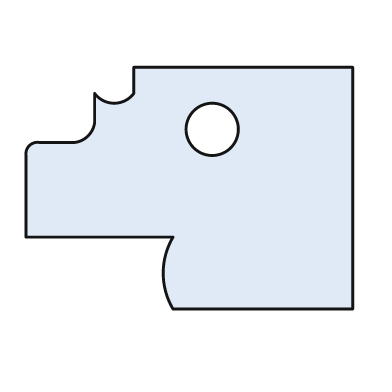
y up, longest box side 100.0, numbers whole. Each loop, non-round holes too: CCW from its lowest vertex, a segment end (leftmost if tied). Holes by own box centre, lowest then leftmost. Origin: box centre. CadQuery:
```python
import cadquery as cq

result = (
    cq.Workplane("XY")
    .moveTo(-5.0, -37.0)
    .lineTo(50.0, -37.0)
    .lineTo(50.0, 37.0)
    .lineTo(-17.0, 37.0)
    .lineTo(-17.0, 29.0)
    .threePointArc((-23.0, 26.0), (-29.0, 29.0))
    .lineTo(-29.0, 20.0)
    .threePointArc((-31.0, 16.0), (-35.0, 14.0))
    .lineTo(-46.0, 14.0)
    .threePointArc((-49.0, 13.0), (-50.0, 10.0))
    .lineTo(-50.0, -15.0)
    .lineTo(-5.0, -15.0)
    .threePointArc((-8.0, -26.0), (-5.0, -37.0))
    .close()
    .moveTo(7.0, 18.0)
    .circle(8.0)
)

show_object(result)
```